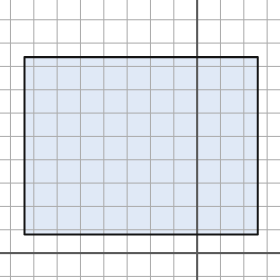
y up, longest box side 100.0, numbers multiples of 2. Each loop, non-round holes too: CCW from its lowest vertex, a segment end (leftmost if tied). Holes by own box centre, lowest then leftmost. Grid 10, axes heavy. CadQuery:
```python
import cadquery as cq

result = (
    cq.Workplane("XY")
    .moveTo(-74.0, 8.0)
    .lineTo(26.0, 8.0)
    .lineTo(26.0, 84.0)
    .lineTo(-74.0, 84.0)
    .close()
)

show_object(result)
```